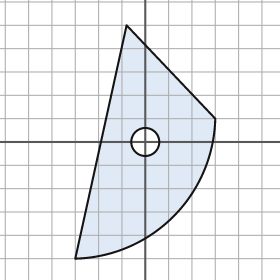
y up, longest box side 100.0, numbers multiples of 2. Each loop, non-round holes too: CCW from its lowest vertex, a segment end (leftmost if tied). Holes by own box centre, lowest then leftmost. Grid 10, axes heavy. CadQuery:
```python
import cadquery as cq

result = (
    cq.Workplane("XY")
    .moveTo(-30.0, -50.0)
    .threePointArc((12.0, -32.0), (30.0, 10.0))
    .lineTo(-8.0, 50.0)
    .close()
    .moveTo(0.0, 0.0)
    .circle(6.0)
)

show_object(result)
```